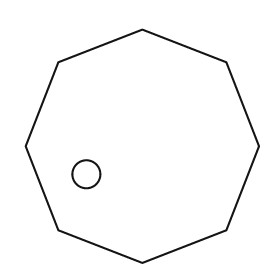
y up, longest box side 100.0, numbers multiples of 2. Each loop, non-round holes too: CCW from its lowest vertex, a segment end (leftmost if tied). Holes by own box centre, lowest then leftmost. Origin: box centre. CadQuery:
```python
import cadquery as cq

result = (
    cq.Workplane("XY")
    .moveTo(0.0, -50.0)
    .lineTo(36.0, -36.0)
    .lineTo(50.0, 0.0)
    .lineTo(36.0, 36.0)
    .lineTo(0.0, 50.0)
    .lineTo(-36.0, 36.0)
    .lineTo(-50.0, 0.0)
    .lineTo(-36.0, -36.0)
    .close()
    .moveTo(-24.0, -12.0)
    .circle(6.0)
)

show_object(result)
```